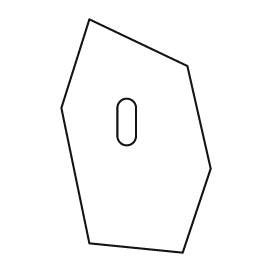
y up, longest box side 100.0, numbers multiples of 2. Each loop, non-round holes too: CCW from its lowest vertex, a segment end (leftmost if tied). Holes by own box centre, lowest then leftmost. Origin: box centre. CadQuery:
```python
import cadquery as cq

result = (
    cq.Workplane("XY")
    .moveTo(20.0, -50.0)
    .lineTo(32.0, -14.0)
    .lineTo(22.0, 30.0)
    .lineTo(-20.0, 50.0)
    .lineTo(-32.0, 12.0)
    .lineTo(-20.0, -46.0)
    .close()
    .moveTo(-8.0, 0.0)
    .threePointArc((-4.0, -4.0), (0.0, 0.0))
    .lineTo(0.0, 12.0)
    .threePointArc((-4.0, 16.0), (-8.0, 12.0))
    .close()
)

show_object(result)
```